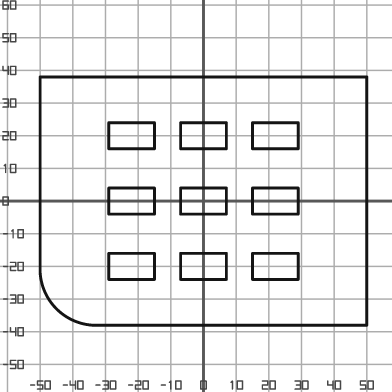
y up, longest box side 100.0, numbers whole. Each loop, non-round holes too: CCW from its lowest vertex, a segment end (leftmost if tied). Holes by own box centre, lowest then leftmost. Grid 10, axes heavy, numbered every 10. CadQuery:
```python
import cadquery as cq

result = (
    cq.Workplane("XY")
    .moveTo(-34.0, -38.0)
    .lineTo(50.0, -38.0)
    .lineTo(50.0, 38.0)
    .lineTo(-50.0, 38.0)
    .lineTo(-50.0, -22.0)
    .threePointArc((-45.0, -33.0), (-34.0, -38.0))
    .close()
    .moveTo(-29.0, -24.0)
    .lineTo(-15.0, -24.0)
    .lineTo(-15.0, -16.0)
    .lineTo(-29.0, -16.0)
    .close()
    .moveTo(-7.0, -24.0)
    .lineTo(7.0, -24.0)
    .lineTo(7.0, -16.0)
    .lineTo(-7.0, -16.0)
    .close()
    .moveTo(15.0, -24.0)
    .lineTo(29.0, -24.0)
    .lineTo(29.0, -16.0)
    .lineTo(15.0, -16.0)
    .close()
    .moveTo(-29.0, -4.0)
    .lineTo(-15.0, -4.0)
    .lineTo(-15.0, 4.0)
    .lineTo(-29.0, 4.0)
    .close()
    .moveTo(-7.0, -4.0)
    .lineTo(7.0, -4.0)
    .lineTo(7.0, 4.0)
    .lineTo(-7.0, 4.0)
    .close()
    .moveTo(15.0, -4.0)
    .lineTo(29.0, -4.0)
    .lineTo(29.0, 4.0)
    .lineTo(15.0, 4.0)
    .close()
    .moveTo(-29.0, 16.0)
    .lineTo(-15.0, 16.0)
    .lineTo(-15.0, 24.0)
    .lineTo(-29.0, 24.0)
    .close()
    .moveTo(-7.0, 16.0)
    .lineTo(7.0, 16.0)
    .lineTo(7.0, 24.0)
    .lineTo(-7.0, 24.0)
    .close()
    .moveTo(15.0, 16.0)
    .lineTo(29.0, 16.0)
    .lineTo(29.0, 24.0)
    .lineTo(15.0, 24.0)
    .close()
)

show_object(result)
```